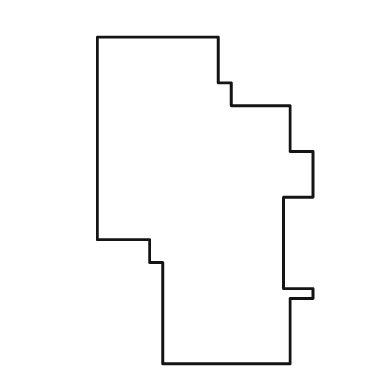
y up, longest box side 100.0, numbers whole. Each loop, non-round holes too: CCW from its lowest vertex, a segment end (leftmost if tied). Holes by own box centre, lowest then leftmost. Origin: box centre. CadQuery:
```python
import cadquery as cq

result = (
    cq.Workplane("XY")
    .moveTo(-13.0, -50.0)
    .lineTo(26.0, -50.0)
    .lineTo(26.0, -30.0)
    .lineTo(33.0, -30.0)
    .lineTo(33.0, -27.0)
    .lineTo(24.0, -27.0)
    .lineTo(24.0, 1.0)
    .lineTo(33.0, 1.0)
    .lineTo(33.0, 15.0)
    .lineTo(26.0, 15.0)
    .lineTo(26.0, 29.0)
    .lineTo(8.0, 29.0)
    .lineTo(8.0, 36.0)
    .lineTo(4.0, 36.0)
    .lineTo(4.0, 50.0)
    .lineTo(-33.0, 50.0)
    .lineTo(-33.0, -12.0)
    .lineTo(-17.0, -12.0)
    .lineTo(-17.0, -19.0)
    .lineTo(-13.0, -19.0)
    .close()
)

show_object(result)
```